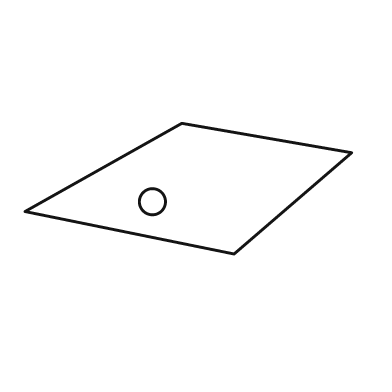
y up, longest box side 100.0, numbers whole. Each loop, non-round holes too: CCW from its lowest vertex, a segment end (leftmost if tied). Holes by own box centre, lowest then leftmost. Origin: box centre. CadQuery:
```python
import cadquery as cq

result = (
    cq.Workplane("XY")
    .moveTo(14.0, -20.0)
    .lineTo(50.0, 11.0)
    .lineTo(-2.0, 20.0)
    .lineTo(-50.0, -7.0)
    .close()
    .moveTo(-11.0, -4.0)
    .circle(4.0)
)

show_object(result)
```